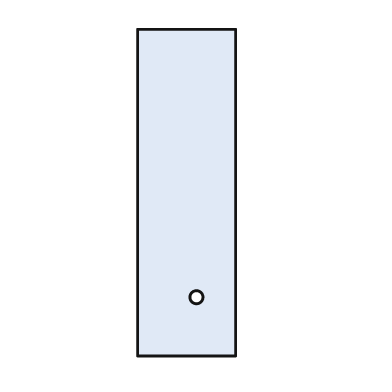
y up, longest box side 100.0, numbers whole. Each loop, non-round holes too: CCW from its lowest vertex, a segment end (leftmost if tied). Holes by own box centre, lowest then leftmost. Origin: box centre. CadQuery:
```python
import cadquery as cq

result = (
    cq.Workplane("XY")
    .moveTo(-15.0, -50.0)
    .lineTo(15.0, -50.0)
    .lineTo(15.0, 50.0)
    .lineTo(-15.0, 50.0)
    .close()
    .moveTo(3.0, -32.0)
    .circle(2.0)
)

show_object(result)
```